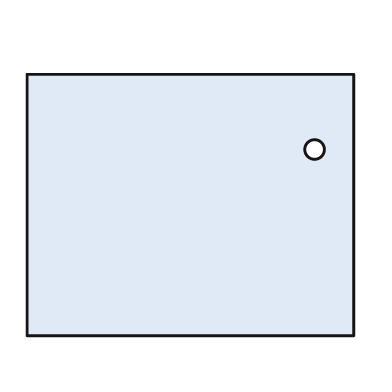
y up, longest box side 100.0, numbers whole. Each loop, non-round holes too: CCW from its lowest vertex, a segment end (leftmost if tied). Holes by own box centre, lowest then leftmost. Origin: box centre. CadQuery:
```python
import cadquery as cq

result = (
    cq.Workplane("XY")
    .moveTo(-50.0, -40.0)
    .lineTo(50.0, -40.0)
    .lineTo(50.0, 40.0)
    .lineTo(-50.0, 40.0)
    .close()
    .moveTo(38.0, 17.0)
    .circle(3.0)
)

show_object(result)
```